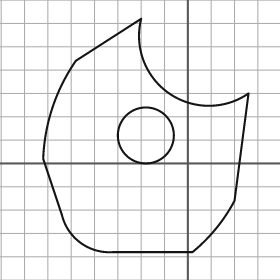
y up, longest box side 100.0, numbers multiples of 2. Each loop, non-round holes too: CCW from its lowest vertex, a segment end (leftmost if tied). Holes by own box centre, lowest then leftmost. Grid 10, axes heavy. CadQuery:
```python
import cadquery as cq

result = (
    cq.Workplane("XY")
    .moveTo(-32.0, -38.0)
    .lineTo(2.0, -38.0)
    .threePointArc((12.0, -28.0), (20.0, -16.0))
    .lineTo(26.0, 30.0)
    .threePointArc((-8.0, 30.0), (-20.0, 62.0))
    .lineTo(-48.0, 44.0)
    .threePointArc((-58.0, 24.0), (-62.0, 2.0))
    .lineTo(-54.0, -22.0)
    .threePointArc((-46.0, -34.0), (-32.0, -38.0))
    .close()
    .moveTo(-18.0, 12.0)
    .circle(12.0)
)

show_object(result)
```